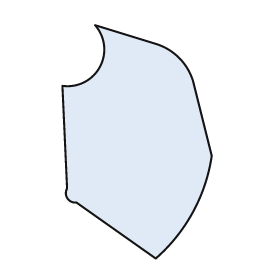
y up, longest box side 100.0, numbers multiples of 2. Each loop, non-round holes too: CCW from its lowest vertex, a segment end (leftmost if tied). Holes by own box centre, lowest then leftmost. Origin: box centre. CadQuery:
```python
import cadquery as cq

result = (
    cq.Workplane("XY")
    .moveTo(8.0, -50.0)
    .threePointArc((24.0, -30.0), (32.0, -6.0))
    .lineTo(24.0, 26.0)
    .threePointArc((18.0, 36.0), (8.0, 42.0))
    .lineTo(-18.0, 50.0)
    .threePointArc((-16.0, 32.0), (-32.0, 24.0))
    .lineTo(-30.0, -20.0)
    .threePointArc((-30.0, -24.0), (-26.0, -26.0))
    .close()
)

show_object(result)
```